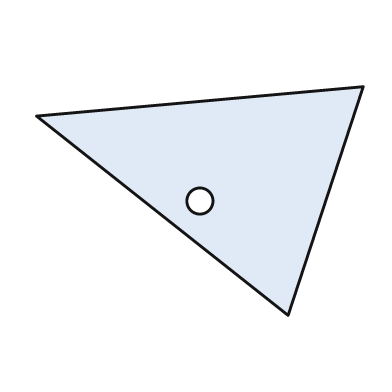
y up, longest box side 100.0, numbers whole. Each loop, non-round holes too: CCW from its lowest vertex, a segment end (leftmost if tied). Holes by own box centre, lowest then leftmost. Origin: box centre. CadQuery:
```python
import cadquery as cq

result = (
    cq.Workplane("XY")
    .moveTo(27.0, -35.0)
    .lineTo(50.0, 35.0)
    .lineTo(-50.0, 26.0)
    .close()
    .moveTo(0.0, 0.0)
    .circle(4.0)
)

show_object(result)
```